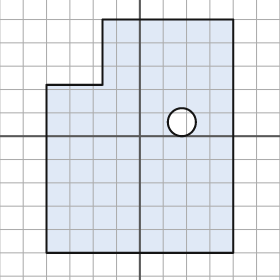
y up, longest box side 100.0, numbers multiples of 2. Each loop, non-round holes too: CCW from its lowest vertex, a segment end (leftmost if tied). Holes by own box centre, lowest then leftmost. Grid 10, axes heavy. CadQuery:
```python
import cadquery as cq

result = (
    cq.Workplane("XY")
    .moveTo(-40.0, -50.0)
    .lineTo(40.0, -50.0)
    .lineTo(40.0, 50.0)
    .lineTo(-16.0, 50.0)
    .lineTo(-16.0, 22.0)
    .lineTo(-40.0, 22.0)
    .close()
    .moveTo(18.0, 6.0)
    .circle(6.0)
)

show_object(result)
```